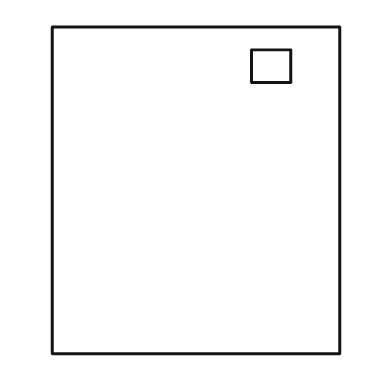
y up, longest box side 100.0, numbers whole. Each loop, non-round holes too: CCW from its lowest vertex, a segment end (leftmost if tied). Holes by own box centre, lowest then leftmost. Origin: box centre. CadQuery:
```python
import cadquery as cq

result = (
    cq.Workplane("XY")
    .moveTo(-44.0, -50.0)
    .lineTo(44.0, -50.0)
    .lineTo(44.0, 50.0)
    .lineTo(-44.0, 50.0)
    .close()
    .moveTo(17.0, 33.0)
    .lineTo(29.0, 33.0)
    .lineTo(29.0, 43.0)
    .lineTo(17.0, 43.0)
    .close()
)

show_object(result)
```